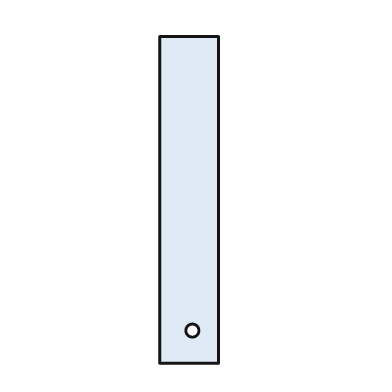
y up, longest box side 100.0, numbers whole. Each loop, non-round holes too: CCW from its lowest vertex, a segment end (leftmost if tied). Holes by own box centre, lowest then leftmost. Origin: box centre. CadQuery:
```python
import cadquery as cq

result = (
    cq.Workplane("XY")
    .moveTo(-9.0, -50.0)
    .lineTo(9.0, -50.0)
    .lineTo(9.0, 50.0)
    .lineTo(-9.0, 50.0)
    .close()
    .moveTo(1.0, -40.0)
    .circle(2.0)
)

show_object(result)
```